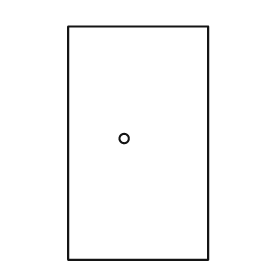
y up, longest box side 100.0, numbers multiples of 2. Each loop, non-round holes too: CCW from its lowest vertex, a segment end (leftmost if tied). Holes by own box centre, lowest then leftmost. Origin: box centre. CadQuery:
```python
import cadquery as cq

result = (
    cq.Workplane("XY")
    .moveTo(-30.0, -50.0)
    .lineTo(30.0, -50.0)
    .lineTo(30.0, 50.0)
    .lineTo(-30.0, 50.0)
    .close()
    .moveTo(-6.0, 2.0)
    .circle(2.0)
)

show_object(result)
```